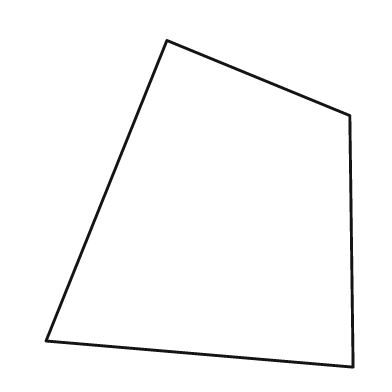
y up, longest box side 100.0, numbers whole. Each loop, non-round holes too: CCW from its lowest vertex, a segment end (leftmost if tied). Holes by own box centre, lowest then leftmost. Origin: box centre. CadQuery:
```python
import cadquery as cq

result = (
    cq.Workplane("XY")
    .moveTo(47.0, -50.0)
    .lineTo(46.0, 27.0)
    .lineTo(-10.0, 50.0)
    .lineTo(-47.0, -42.0)
    .close()
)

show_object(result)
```